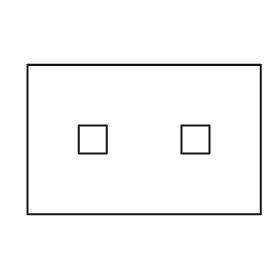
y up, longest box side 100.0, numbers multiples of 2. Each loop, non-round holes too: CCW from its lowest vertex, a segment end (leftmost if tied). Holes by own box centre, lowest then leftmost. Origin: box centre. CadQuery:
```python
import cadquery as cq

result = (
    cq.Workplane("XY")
    .moveTo(-50.0, -32.0)
    .lineTo(50.0, -32.0)
    .lineTo(50.0, 32.0)
    .lineTo(-50.0, 32.0)
    .close()
    .moveTo(-28.0, -6.0)
    .lineTo(-16.0, -6.0)
    .lineTo(-16.0, 6.0)
    .lineTo(-28.0, 6.0)
    .close()
    .moveTo(16.0, -6.0)
    .lineTo(28.0, -6.0)
    .lineTo(28.0, 6.0)
    .lineTo(16.0, 6.0)
    .close()
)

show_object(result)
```